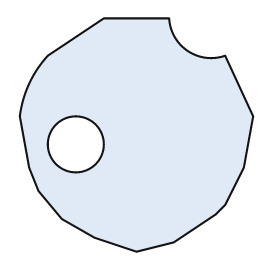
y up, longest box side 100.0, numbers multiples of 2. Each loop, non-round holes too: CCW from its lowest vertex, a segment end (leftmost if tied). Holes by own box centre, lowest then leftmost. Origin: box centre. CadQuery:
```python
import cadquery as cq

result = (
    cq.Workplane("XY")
    .moveTo(0.0, -50.0)
    .lineTo(16.0, -46.0)
    .lineTo(34.0, -34.0)
    .lineTo(38.0, -30.0)
    .lineTo(46.0, -14.0)
    .lineTo(50.0, 8.0)
    .lineTo(38.0, 34.0)
    .threePointArc((22.0, 36.0), (14.0, 50.0))
    .lineTo(-14.0, 50.0)
    .lineTo(-38.0, 34.0)
    .threePointArc((-46.0, 22.0), (-50.0, 8.0))
    .lineTo(-46.0, -14.0)
    .lineTo(-42.0, -24.0)
    .lineTo(-32.0, -36.0)
    .lineTo(-18.0, -44.0)
    .close()
    .moveTo(-26.0, -4.0)
    .circle(12.0)
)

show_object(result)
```